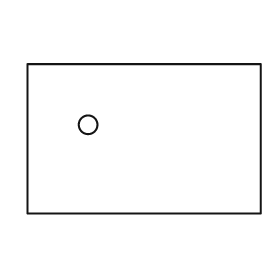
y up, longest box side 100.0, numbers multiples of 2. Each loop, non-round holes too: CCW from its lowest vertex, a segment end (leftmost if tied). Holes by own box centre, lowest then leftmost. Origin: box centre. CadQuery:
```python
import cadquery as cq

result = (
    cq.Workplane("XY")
    .moveTo(-50.0, -32.0)
    .lineTo(50.0, -32.0)
    .lineTo(50.0, 32.0)
    .lineTo(-50.0, 32.0)
    .close()
    .moveTo(-24.0, 6.0)
    .circle(4.0)
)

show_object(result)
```